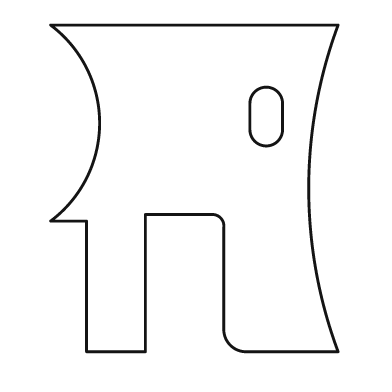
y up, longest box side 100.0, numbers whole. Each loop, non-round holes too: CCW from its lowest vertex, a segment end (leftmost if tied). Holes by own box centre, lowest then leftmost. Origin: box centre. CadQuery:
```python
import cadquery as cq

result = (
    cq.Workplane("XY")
    .moveTo(-33.0, -50.0)
    .lineTo(-15.0, -50.0)
    .lineTo(-15.0, -8.0)
    .lineTo(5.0, -8.0)
    .threePointArc((8.0, -9.0), (9.0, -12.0))
    .lineTo(9.0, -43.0)
    .threePointArc((11.0, -48.0), (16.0, -50.0))
    .lineTo(44.0, -50.0)
    .threePointArc((35.0, 0.0), (44.0, 50.0))
    .lineTo(-44.0, 50.0)
    .threePointArc((-29.0, 20.0), (-44.0, -10.0))
    .lineTo(-33.0, -10.0)
    .close()
    .moveTo(17.0, 18.0)
    .threePointArc((22.0, 13.0), (27.0, 18.0))
    .lineTo(27.0, 26.0)
    .threePointArc((22.0, 31.0), (17.0, 26.0))
    .close()
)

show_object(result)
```